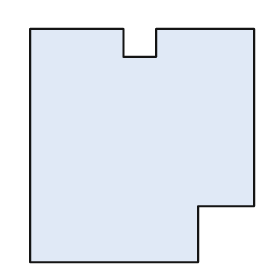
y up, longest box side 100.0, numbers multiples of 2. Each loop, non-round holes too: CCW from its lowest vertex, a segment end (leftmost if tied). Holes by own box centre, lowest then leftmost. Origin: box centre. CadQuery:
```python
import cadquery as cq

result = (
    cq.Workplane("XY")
    .moveTo(-48.0, -50.0)
    .lineTo(24.0, -50.0)
    .lineTo(24.0, -26.0)
    .lineTo(48.0, -26.0)
    .lineTo(48.0, 50.0)
    .lineTo(6.0, 50.0)
    .lineTo(6.0, 38.0)
    .lineTo(-8.0, 38.0)
    .lineTo(-8.0, 50.0)
    .lineTo(-48.0, 50.0)
    .close()
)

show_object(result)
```